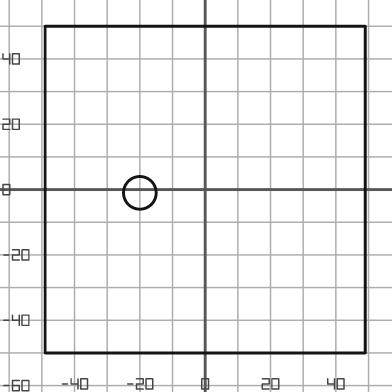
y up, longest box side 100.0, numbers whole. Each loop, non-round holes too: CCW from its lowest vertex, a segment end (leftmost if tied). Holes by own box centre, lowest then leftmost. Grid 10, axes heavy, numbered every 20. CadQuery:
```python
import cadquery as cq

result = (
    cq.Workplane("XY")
    .moveTo(-49.0, -50.0)
    .lineTo(49.0, -50.0)
    .lineTo(49.0, 50.0)
    .lineTo(-49.0, 50.0)
    .close()
    .moveTo(-20.0, -1.0)
    .circle(5.0)
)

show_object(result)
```